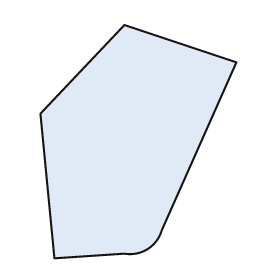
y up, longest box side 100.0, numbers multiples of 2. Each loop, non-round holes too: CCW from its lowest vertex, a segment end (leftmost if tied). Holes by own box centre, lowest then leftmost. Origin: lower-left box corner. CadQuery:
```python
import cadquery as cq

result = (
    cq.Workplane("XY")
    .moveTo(6.0, 0.0)
    .lineTo(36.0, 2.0)
    .threePointArc((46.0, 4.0), (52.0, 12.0))
    .lineTo(84.0, 84.0)
    .lineTo(36.0, 100.0)
    .lineTo(0.0, 62.0)
    .close()
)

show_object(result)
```